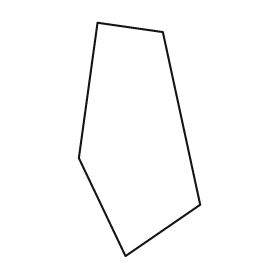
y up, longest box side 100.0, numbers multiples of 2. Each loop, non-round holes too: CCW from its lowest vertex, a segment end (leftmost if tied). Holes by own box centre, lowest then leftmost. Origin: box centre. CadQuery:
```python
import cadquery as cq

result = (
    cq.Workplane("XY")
    .moveTo(-6.0, -50.0)
    .lineTo(26.0, -28.0)
    .lineTo(10.0, 46.0)
    .lineTo(-18.0, 50.0)
    .lineTo(-26.0, -8.0)
    .close()
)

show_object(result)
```